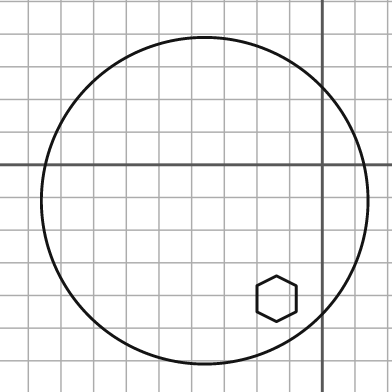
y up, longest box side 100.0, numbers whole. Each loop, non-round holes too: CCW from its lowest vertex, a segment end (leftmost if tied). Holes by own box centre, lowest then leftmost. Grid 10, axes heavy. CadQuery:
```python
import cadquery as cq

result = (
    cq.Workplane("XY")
    .moveTo(-36.0, -11.0)
    .circle(50.0)
    .moveTo(-14.0, -48.0)
    .lineTo(-8.0, -45.0)
    .lineTo(-8.0, -37.0)
    .lineTo(-14.0, -34.0)
    .lineTo(-20.0, -37.0)
    .lineTo(-20.0, -45.0)
    .close()
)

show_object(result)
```